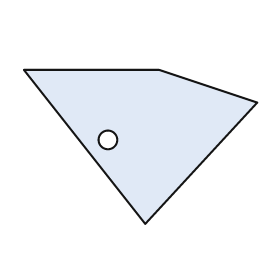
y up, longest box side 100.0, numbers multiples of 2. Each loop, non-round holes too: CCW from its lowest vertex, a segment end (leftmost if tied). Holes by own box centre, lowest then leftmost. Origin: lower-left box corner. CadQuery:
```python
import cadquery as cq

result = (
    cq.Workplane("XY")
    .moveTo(52.0, 0.0)
    .lineTo(100.0, 52.0)
    .lineTo(58.0, 66.0)
    .lineTo(0.0, 66.0)
    .close()
    .moveTo(36.0, 36.0)
    .circle(4.0)
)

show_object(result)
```